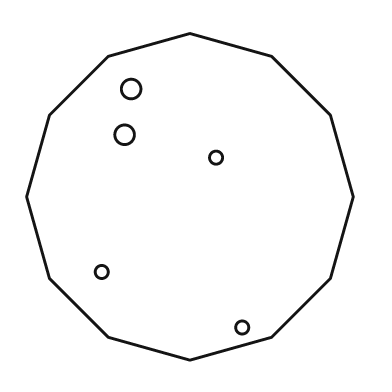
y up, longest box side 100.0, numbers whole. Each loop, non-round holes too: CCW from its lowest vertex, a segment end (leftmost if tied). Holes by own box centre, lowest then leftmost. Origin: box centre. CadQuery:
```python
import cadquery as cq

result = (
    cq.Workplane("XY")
    .moveTo(0.0, -50.0)
    .lineTo(25.0, -43.0)
    .lineTo(43.0, -25.0)
    .lineTo(50.0, 0.0)
    .lineTo(43.0, 25.0)
    .lineTo(25.0, 43.0)
    .lineTo(0.0, 50.0)
    .lineTo(-25.0, 43.0)
    .lineTo(-43.0, 25.0)
    .lineTo(-50.0, 0.0)
    .lineTo(-43.0, -25.0)
    .lineTo(-25.0, -43.0)
    .close()
    .moveTo(16.0, -40.0)
    .circle(2.0)
    .moveTo(-27.0, -23.0)
    .circle(2.0)
    .moveTo(8.0, 12.0)
    .circle(2.0)
    .moveTo(-20.0, 19.0)
    .circle(3.0)
    .moveTo(-18.0, 33.0)
    .circle(3.0)
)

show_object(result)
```